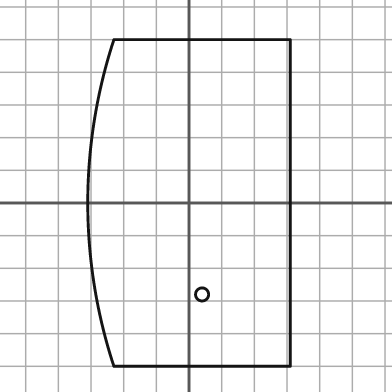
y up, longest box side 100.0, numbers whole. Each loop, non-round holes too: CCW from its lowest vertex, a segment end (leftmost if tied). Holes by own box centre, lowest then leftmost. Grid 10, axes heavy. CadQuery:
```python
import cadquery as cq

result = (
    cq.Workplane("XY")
    .moveTo(-23.0, -50.0)
    .lineTo(31.0, -50.0)
    .lineTo(31.0, 50.0)
    .lineTo(-23.0, 50.0)
    .threePointArc((-31.0, 0.0), (-23.0, -50.0))
    .close()
    .moveTo(4.0, -28.0)
    .circle(2.0)
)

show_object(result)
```